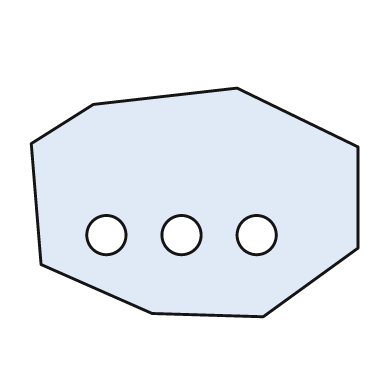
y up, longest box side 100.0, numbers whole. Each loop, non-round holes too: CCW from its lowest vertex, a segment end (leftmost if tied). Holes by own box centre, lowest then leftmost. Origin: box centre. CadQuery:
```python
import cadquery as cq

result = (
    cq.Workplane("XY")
    .moveTo(21.0, -35.0)
    .lineTo(50.0, -14.0)
    .lineTo(50.0, 17.0)
    .lineTo(13.0, 35.0)
    .lineTo(-31.0, 30.0)
    .lineTo(-50.0, 18.0)
    .lineTo(-47.0, -19.0)
    .lineTo(-13.0, -34.0)
    .close()
    .moveTo(-27.0, -10.0)
    .circle(6.0)
    .moveTo(-4.0, -10.0)
    .circle(6.0)
    .moveTo(19.0, -10.0)
    .circle(6.0)
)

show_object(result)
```